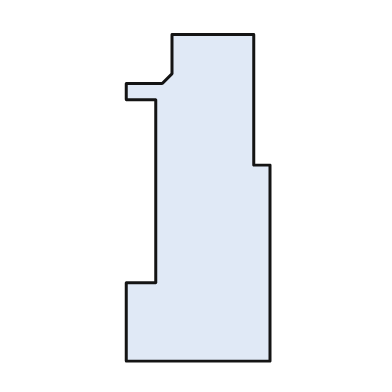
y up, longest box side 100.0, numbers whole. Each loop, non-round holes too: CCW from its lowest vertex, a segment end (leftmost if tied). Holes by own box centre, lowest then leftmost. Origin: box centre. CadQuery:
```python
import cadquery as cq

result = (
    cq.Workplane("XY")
    .moveTo(-22.0, -50.0)
    .lineTo(22.0, -50.0)
    .lineTo(22.0, 10.0)
    .lineTo(17.0, 10.0)
    .lineTo(17.0, 50.0)
    .lineTo(-8.0, 50.0)
    .lineTo(-8.0, 38.0)
    .lineTo(-11.0, 35.0)
    .lineTo(-22.0, 35.0)
    .lineTo(-22.0, 30.0)
    .lineTo(-13.0, 30.0)
    .lineTo(-13.0, -26.0)
    .lineTo(-22.0, -26.0)
    .close()
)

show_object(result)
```